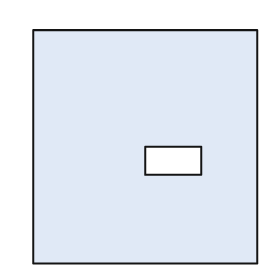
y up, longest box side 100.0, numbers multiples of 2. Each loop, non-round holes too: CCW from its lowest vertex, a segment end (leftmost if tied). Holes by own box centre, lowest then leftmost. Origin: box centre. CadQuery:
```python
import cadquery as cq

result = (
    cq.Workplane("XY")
    .moveTo(-48.0, -50.0)
    .lineTo(48.0, -50.0)
    .lineTo(48.0, 50.0)
    .lineTo(-48.0, 50.0)
    .close()
    .moveTo(0.0, -12.0)
    .lineTo(24.0, -12.0)
    .lineTo(24.0, 0.0)
    .lineTo(0.0, 0.0)
    .close()
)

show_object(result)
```